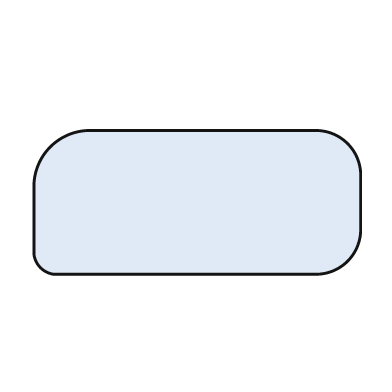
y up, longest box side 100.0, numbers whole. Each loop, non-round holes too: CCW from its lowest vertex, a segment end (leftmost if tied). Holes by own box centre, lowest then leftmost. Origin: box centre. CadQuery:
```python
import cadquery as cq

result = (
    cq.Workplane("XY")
    .moveTo(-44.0, -22.0)
    .lineTo(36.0, -22.0)
    .threePointArc((46.0, -18.0), (50.0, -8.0))
    .lineTo(50.0, 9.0)
    .threePointArc((46.0, 18.0), (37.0, 22.0))
    .lineTo(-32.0, 22.0)
    .threePointArc((-45.0, 17.0), (-50.0, 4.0))
    .lineTo(-50.0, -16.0)
    .threePointArc((-48.0, -20.0), (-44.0, -22.0))
    .close()
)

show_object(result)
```